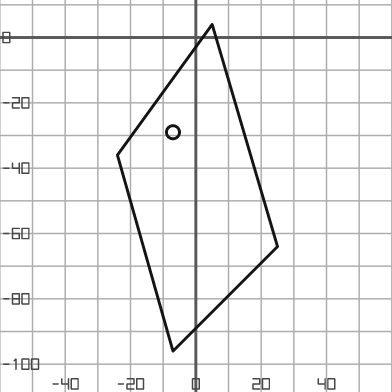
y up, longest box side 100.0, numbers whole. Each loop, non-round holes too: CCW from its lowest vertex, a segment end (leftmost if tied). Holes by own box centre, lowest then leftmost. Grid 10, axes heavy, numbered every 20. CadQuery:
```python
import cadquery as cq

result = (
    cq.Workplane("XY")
    .moveTo(-7.0, -96.0)
    .lineTo(25.0, -64.0)
    .lineTo(5.0, 4.0)
    .lineTo(-24.0, -36.0)
    .close()
    .moveTo(-7.0, -29.0)
    .circle(2.0)
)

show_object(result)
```